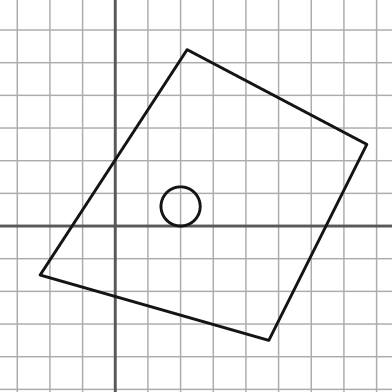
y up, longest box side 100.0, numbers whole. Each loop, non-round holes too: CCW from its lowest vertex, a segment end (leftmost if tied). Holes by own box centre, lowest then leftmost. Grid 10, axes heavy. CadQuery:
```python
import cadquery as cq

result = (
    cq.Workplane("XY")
    .moveTo(47.0, -35.0)
    .lineTo(77.0, 25.0)
    .lineTo(22.0, 54.0)
    .lineTo(-23.0, -15.0)
    .close()
    .moveTo(20.0, 6.0)
    .circle(6.0)
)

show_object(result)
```